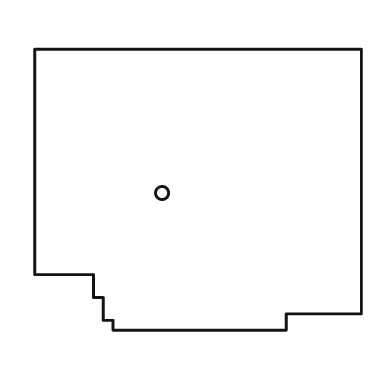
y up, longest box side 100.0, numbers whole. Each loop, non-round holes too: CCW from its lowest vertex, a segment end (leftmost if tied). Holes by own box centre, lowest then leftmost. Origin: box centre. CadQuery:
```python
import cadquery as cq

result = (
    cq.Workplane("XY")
    .moveTo(-26.0, -43.0)
    .lineTo(27.0, -43.0)
    .lineTo(27.0, -38.0)
    .lineTo(50.0, -38.0)
    .lineTo(50.0, 43.0)
    .lineTo(-50.0, 43.0)
    .lineTo(-50.0, -26.0)
    .lineTo(-32.0, -26.0)
    .lineTo(-32.0, -33.0)
    .lineTo(-29.0, -33.0)
    .lineTo(-29.0, -40.0)
    .lineTo(-26.0, -40.0)
    .close()
    .moveTo(-11.0, -1.0)
    .circle(2.0)
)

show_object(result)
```